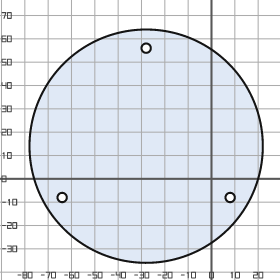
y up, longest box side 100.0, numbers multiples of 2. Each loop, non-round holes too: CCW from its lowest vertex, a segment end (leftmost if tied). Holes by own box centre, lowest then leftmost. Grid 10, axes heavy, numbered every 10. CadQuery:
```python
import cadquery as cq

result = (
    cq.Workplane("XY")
    .moveTo(-28.0, 14.0)
    .circle(50.0)
    .moveTo(-64.0, -8.0)
    .circle(2.0)
    .moveTo(8.0, -8.0)
    .circle(2.0)
    .moveTo(-28.0, 56.0)
    .circle(2.0)
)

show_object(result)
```